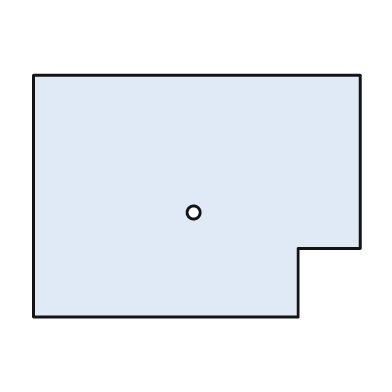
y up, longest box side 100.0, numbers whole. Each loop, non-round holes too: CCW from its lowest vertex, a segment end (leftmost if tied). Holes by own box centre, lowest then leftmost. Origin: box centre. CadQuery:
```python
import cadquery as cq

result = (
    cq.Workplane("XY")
    .moveTo(-50.0, -37.0)
    .lineTo(31.0, -37.0)
    .lineTo(31.0, -16.0)
    .lineTo(50.0, -16.0)
    .lineTo(50.0, 37.0)
    .lineTo(-50.0, 37.0)
    .close()
    .moveTo(-1.0, -5.0)
    .circle(2.0)
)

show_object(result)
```